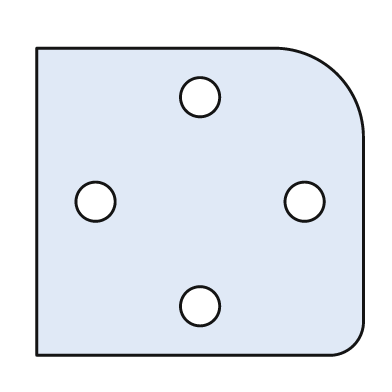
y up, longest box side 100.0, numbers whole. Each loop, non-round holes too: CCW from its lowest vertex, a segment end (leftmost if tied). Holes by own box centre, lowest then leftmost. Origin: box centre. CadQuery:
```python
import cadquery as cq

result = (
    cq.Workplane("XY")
    .moveTo(-50.0, -47.0)
    .lineTo(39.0, -47.0)
    .threePointArc((47.0, -44.0), (50.0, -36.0))
    .lineTo(50.0, 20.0)
    .threePointArc((42.0, 39.0), (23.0, 47.0))
    .lineTo(-50.0, 47.0)
    .close()
    .moveTo(0.0, -32.0)
    .circle(6.0)
    .moveTo(-32.0, 0.0)
    .circle(6.0)
    .moveTo(32.0, 0.0)
    .circle(6.0)
    .moveTo(0.0, 32.0)
    .circle(6.0)
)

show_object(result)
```